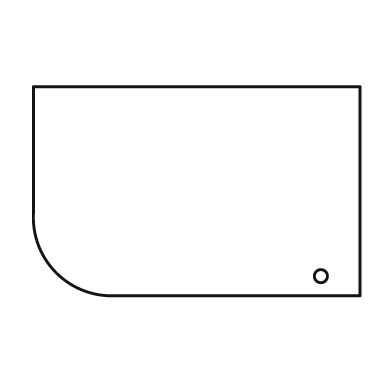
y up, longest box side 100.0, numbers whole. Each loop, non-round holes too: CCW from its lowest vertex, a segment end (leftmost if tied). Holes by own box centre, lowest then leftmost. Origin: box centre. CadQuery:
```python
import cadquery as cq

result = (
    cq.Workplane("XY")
    .moveTo(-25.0, -32.0)
    .lineTo(50.0, -32.0)
    .lineTo(50.0, 32.0)
    .lineTo(-50.0, 32.0)
    .lineTo(-50.0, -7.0)
    .threePointArc((-43.0, -25.0), (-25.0, -32.0))
    .close()
    .moveTo(38.0, -26.0)
    .circle(2.0)
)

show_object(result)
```